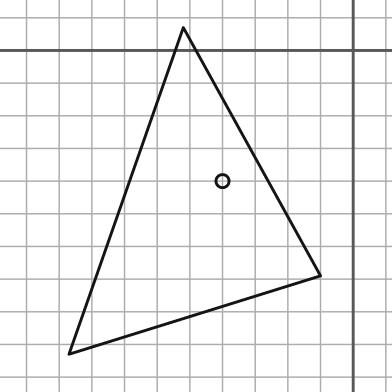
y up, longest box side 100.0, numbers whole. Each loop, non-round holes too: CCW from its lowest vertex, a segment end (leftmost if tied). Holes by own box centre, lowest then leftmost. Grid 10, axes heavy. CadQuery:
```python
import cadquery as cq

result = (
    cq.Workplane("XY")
    .moveTo(-87.0, -93.0)
    .lineTo(-10.0, -69.0)
    .lineTo(-52.0, 7.0)
    .close()
    .moveTo(-40.0, -40.0)
    .circle(2.0)
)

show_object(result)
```